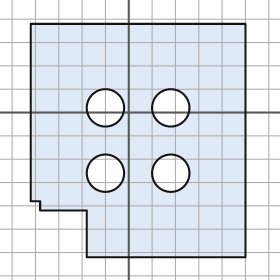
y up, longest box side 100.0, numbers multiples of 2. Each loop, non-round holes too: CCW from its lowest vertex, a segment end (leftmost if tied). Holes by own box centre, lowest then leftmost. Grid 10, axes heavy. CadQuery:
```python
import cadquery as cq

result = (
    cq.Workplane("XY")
    .moveTo(-18.0, -62.0)
    .lineTo(50.0, -62.0)
    .lineTo(50.0, 38.0)
    .lineTo(-42.0, 38.0)
    .lineTo(-42.0, -38.0)
    .lineTo(-38.0, -38.0)
    .lineTo(-38.0, -42.0)
    .lineTo(-18.0, -42.0)
    .close()
    .moveTo(-10.0, -26.0)
    .circle(8.0)
    .moveTo(18.0, -26.0)
    .circle(8.0)
    .moveTo(-10.0, 2.0)
    .circle(8.0)
    .moveTo(18.0, 2.0)
    .circle(8.0)
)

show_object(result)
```